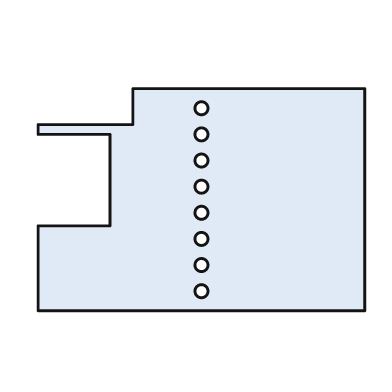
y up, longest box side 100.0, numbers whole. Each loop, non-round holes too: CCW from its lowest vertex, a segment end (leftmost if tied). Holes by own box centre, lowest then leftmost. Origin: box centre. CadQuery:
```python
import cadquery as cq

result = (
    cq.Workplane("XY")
    .moveTo(-50.0, -34.0)
    .lineTo(50.0, -34.0)
    .lineTo(50.0, 34.0)
    .lineTo(-21.0, 34.0)
    .lineTo(-21.0, 23.0)
    .lineTo(-50.0, 23.0)
    .lineTo(-50.0, 20.0)
    .lineTo(-28.0, 20.0)
    .lineTo(-28.0, -8.0)
    .lineTo(-50.0, -8.0)
    .close()
    .moveTo(0.0, -28.0)
    .circle(2.0)
    .moveTo(0.0, -20.0)
    .circle(2.0)
    .moveTo(0.0, -12.0)
    .circle(2.0)
    .moveTo(0.0, -4.0)
    .circle(2.0)
    .moveTo(0.0, 4.0)
    .circle(2.0)
    .moveTo(0.0, 12.0)
    .circle(2.0)
    .moveTo(0.0, 20.0)
    .circle(2.0)
    .moveTo(0.0, 28.0)
    .circle(2.0)
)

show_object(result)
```